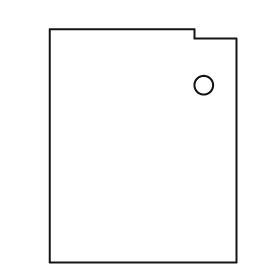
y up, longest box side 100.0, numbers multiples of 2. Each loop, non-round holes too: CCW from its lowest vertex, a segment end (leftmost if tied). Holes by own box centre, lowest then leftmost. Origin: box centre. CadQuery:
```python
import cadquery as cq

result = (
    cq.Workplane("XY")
    .moveTo(-40.0, -50.0)
    .lineTo(40.0, -50.0)
    .lineTo(40.0, 46.0)
    .lineTo(22.0, 46.0)
    .lineTo(22.0, 50.0)
    .lineTo(-40.0, 50.0)
    .close()
    .moveTo(26.0, 26.0)
    .circle(4.0)
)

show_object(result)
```